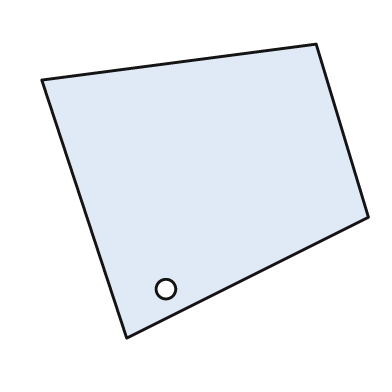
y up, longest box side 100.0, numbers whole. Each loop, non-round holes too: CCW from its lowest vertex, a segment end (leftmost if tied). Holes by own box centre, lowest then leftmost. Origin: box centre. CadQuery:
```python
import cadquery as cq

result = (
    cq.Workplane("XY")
    .moveTo(-24.0, -45.0)
    .lineTo(50.0, -8.0)
    .lineTo(34.0, 45.0)
    .lineTo(-50.0, 34.0)
    .close()
    .moveTo(-12.0, -30.0)
    .circle(3.0)
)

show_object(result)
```